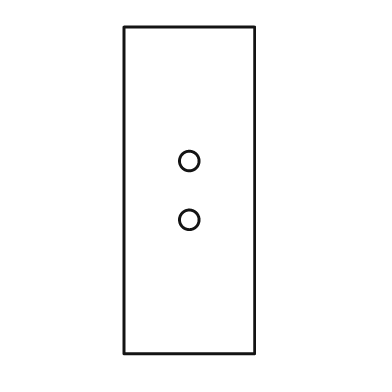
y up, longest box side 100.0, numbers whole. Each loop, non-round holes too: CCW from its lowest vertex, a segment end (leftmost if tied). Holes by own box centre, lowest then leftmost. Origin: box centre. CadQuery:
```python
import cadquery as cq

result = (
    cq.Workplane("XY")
    .moveTo(-20.0, -50.0)
    .lineTo(20.0, -50.0)
    .lineTo(20.0, 50.0)
    .lineTo(-20.0, 50.0)
    .close()
    .moveTo(0.0, -9.0)
    .circle(3.0)
    .moveTo(0.0, 9.0)
    .circle(3.0)
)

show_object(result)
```